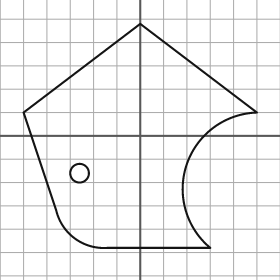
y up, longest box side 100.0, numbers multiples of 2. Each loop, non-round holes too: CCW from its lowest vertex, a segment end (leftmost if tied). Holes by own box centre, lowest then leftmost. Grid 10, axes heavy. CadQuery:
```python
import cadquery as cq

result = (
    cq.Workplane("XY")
    .moveTo(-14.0, -48.0)
    .lineTo(30.0, -48.0)
    .threePointArc((20.0, -12.0), (50.0, 10.0))
    .lineTo(0.0, 48.0)
    .lineTo(-50.0, 10.0)
    .lineTo(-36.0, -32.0)
    .threePointArc((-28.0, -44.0), (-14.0, -48.0))
    .close()
    .moveTo(-26.0, -16.0)
    .circle(4.0)
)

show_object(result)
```